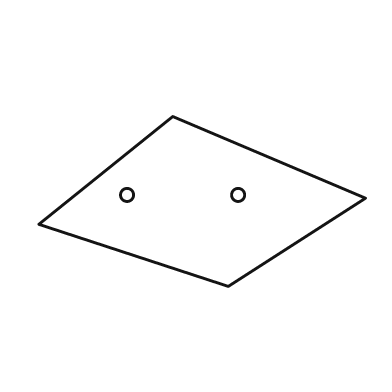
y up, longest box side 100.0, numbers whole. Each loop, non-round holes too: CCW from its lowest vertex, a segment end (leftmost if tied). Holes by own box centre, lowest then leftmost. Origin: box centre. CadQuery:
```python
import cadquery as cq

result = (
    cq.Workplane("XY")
    .moveTo(8.0, -26.0)
    .lineTo(50.0, 1.0)
    .lineTo(-9.0, 26.0)
    .lineTo(-50.0, -7.0)
    .close()
    .moveTo(-23.0, 2.0)
    .circle(2.0)
    .moveTo(11.0, 2.0)
    .circle(2.0)
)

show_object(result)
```